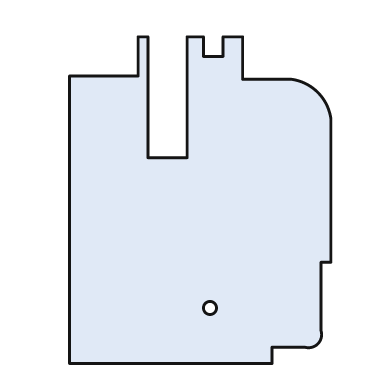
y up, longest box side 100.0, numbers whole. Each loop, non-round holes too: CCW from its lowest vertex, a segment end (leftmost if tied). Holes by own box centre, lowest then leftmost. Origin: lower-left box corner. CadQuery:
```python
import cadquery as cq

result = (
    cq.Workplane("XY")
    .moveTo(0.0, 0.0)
    .lineTo(62.0, 0.0)
    .lineTo(62.0, 5.0)
    .lineTo(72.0, 5.0)
    .threePointArc((76.0, 6.0), (77.0, 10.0))
    .lineTo(77.0, 31.0)
    .lineTo(80.0, 31.0)
    .lineTo(80.0, 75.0)
    .threePointArc((76.0, 83.0), (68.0, 87.0))
    .lineTo(53.0, 87.0)
    .lineTo(53.0, 100.0)
    .lineTo(47.0, 100.0)
    .lineTo(47.0, 94.0)
    .lineTo(41.0, 94.0)
    .lineTo(41.0, 100.0)
    .lineTo(36.0, 100.0)
    .lineTo(36.0, 63.0)
    .lineTo(24.0, 63.0)
    .lineTo(24.0, 100.0)
    .lineTo(21.0, 100.0)
    .lineTo(21.0, 88.0)
    .lineTo(0.0, 88.0)
    .close()
    .moveTo(43.0, 17.0)
    .circle(2.0)
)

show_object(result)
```